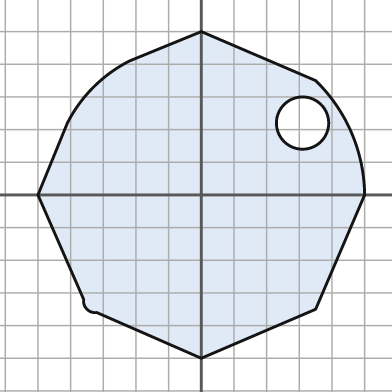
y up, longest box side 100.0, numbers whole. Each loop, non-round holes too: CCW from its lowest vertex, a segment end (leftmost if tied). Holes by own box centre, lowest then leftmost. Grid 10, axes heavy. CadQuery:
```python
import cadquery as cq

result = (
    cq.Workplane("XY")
    .moveTo(0.0, -50.0)
    .lineTo(35.0, -35.0)
    .lineTo(50.0, 0.0)
    .threePointArc((46.0, 19.0), (35.0, 35.0))
    .lineTo(0.0, 50.0)
    .lineTo(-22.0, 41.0)
    .threePointArc((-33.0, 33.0), (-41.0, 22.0))
    .lineTo(-50.0, 0.0)
    .lineTo(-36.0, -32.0)
    .threePointArc((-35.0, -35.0), (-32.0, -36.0))
    .close()
    .moveTo(31.0, 22.0)
    .circle(8.0)
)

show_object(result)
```